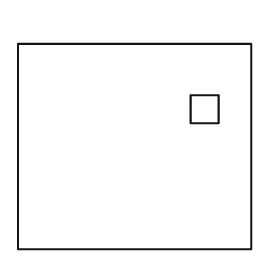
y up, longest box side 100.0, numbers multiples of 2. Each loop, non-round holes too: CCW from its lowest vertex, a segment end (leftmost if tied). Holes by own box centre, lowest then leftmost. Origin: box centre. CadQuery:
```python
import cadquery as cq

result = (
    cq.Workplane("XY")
    .moveTo(-50.0, -44.0)
    .lineTo(50.0, -44.0)
    .lineTo(50.0, 44.0)
    .lineTo(-50.0, 44.0)
    .close()
    .moveTo(24.0, 10.0)
    .lineTo(36.0, 10.0)
    .lineTo(36.0, 22.0)
    .lineTo(24.0, 22.0)
    .close()
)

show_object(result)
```